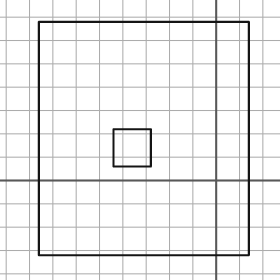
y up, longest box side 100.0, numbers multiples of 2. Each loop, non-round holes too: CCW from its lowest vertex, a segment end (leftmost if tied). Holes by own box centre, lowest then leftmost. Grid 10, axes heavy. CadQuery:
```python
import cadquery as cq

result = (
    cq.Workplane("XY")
    .moveTo(-76.0, -32.0)
    .lineTo(14.0, -32.0)
    .lineTo(14.0, 68.0)
    .lineTo(-76.0, 68.0)
    .close()
    .moveTo(-44.0, 6.0)
    .lineTo(-28.0, 6.0)
    .lineTo(-28.0, 22.0)
    .lineTo(-44.0, 22.0)
    .close()
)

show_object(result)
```